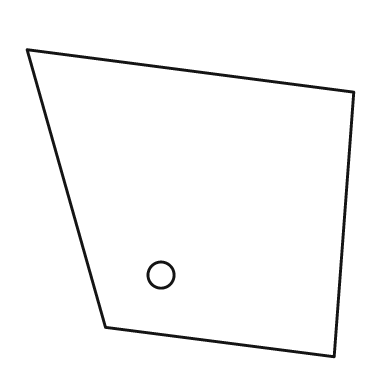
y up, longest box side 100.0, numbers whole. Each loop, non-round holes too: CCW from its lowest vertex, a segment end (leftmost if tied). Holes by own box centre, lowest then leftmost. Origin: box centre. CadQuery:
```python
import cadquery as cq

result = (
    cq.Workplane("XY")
    .moveTo(44.0, -47.0)
    .lineTo(50.0, 34.0)
    .lineTo(-50.0, 47.0)
    .lineTo(-26.0, -38.0)
    .close()
    .moveTo(-9.0, -22.0)
    .circle(4.0)
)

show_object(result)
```